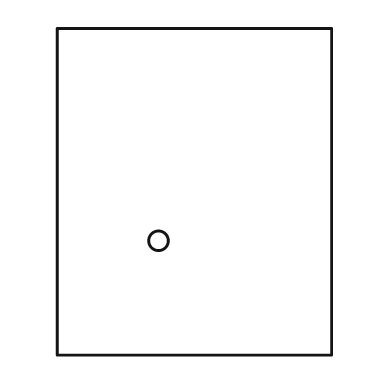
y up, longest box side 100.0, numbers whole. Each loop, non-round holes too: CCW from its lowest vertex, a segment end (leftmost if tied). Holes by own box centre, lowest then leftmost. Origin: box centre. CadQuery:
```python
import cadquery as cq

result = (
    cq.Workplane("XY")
    .moveTo(-42.0, -50.0)
    .lineTo(42.0, -50.0)
    .lineTo(42.0, 50.0)
    .lineTo(-42.0, 50.0)
    .close()
    .moveTo(-11.0, -15.0)
    .circle(3.0)
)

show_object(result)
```